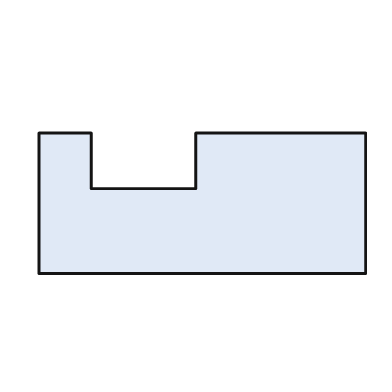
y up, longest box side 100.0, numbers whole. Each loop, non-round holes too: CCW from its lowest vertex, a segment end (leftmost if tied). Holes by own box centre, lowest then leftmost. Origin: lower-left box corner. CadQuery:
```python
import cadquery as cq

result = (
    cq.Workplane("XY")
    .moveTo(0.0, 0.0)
    .lineTo(100.0, 0.0)
    .lineTo(100.0, 43.0)
    .lineTo(48.0, 43.0)
    .lineTo(48.0, 26.0)
    .lineTo(16.0, 26.0)
    .lineTo(16.0, 43.0)
    .lineTo(0.0, 43.0)
    .close()
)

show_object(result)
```